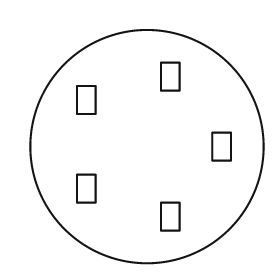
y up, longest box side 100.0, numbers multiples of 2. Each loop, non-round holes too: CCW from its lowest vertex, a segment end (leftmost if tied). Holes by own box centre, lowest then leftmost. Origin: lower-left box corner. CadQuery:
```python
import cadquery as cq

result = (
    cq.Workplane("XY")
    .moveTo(50.0, 50.0)
    .circle(50.0)
    .moveTo(56.0, 14.0)
    .lineTo(64.0, 14.0)
    .lineTo(64.0, 26.0)
    .lineTo(56.0, 26.0)
    .close()
    .moveTo(20.0, 26.0)
    .lineTo(28.0, 26.0)
    .lineTo(28.0, 38.0)
    .lineTo(20.0, 38.0)
    .close()
    .moveTo(78.0, 44.0)
    .lineTo(86.0, 44.0)
    .lineTo(86.0, 56.0)
    .lineTo(78.0, 56.0)
    .close()
    .moveTo(20.0, 64.0)
    .lineTo(28.0, 64.0)
    .lineTo(28.0, 76.0)
    .lineTo(20.0, 76.0)
    .close()
    .moveTo(56.0, 74.0)
    .lineTo(64.0, 74.0)
    .lineTo(64.0, 86.0)
    .lineTo(56.0, 86.0)
    .close()
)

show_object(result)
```